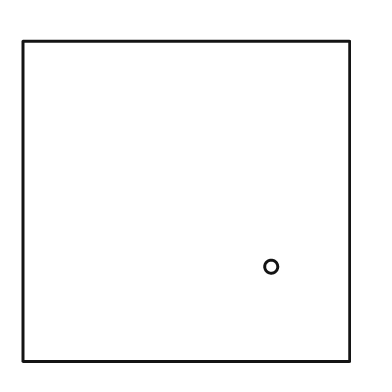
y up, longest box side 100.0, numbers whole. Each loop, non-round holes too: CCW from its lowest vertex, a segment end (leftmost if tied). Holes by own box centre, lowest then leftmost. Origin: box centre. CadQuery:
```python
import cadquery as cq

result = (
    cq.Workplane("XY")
    .moveTo(-50.0, -49.0)
    .lineTo(50.0, -49.0)
    .lineTo(50.0, 49.0)
    .lineTo(-50.0, 49.0)
    .close()
    .moveTo(26.0, -20.0)
    .circle(2.0)
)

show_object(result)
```